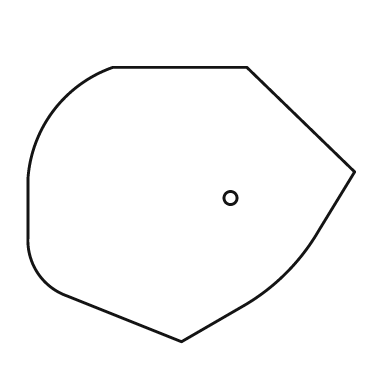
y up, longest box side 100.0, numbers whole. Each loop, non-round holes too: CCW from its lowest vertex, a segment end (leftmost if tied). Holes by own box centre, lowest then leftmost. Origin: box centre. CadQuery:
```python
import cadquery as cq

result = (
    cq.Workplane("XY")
    .moveTo(-3.0, -42.0)
    .lineTo(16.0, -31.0)
    .threePointArc((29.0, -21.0), (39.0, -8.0))
    .lineTo(50.0, 10.0)
    .lineTo(17.0, 42.0)
    .lineTo(-24.0, 42.0)
    .threePointArc((-42.0, 29.0), (-50.0, 8.0))
    .lineTo(-50.0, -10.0)
    .threePointArc((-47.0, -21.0), (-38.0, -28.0))
    .close()
    .moveTo(12.0, 2.0)
    .circle(2.0)
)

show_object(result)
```